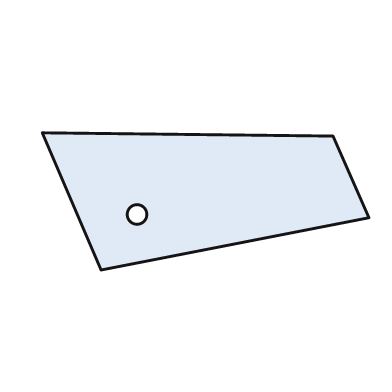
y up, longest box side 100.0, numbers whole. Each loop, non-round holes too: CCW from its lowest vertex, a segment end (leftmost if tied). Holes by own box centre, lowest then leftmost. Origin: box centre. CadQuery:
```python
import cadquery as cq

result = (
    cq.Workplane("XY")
    .moveTo(-32.0, -21.0)
    .lineTo(50.0, -5.0)
    .lineTo(39.0, 20.0)
    .lineTo(-50.0, 21.0)
    .close()
    .moveTo(-21.0, -4.0)
    .circle(3.0)
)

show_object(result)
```